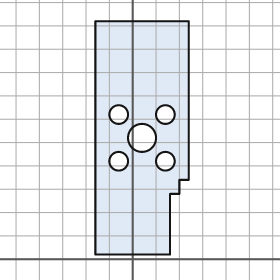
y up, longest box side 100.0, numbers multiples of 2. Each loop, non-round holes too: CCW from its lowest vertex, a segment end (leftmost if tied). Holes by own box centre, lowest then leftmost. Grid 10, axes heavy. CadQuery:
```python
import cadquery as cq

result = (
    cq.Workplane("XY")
    .moveTo(-16.0, 2.0)
    .lineTo(16.0, 2.0)
    .lineTo(16.0, 28.0)
    .lineTo(20.0, 28.0)
    .lineTo(20.0, 34.0)
    .lineTo(24.0, 34.0)
    .lineTo(24.0, 102.0)
    .lineTo(-16.0, 102.0)
    .close()
    .moveTo(-6.0, 42.0)
    .circle(4.0)
    .moveTo(14.0, 42.0)
    .circle(4.0)
    .moveTo(4.0, 52.0)
    .circle(6.0)
    .moveTo(-6.0, 62.0)
    .circle(4.0)
    .moveTo(14.0, 62.0)
    .circle(4.0)
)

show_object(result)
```